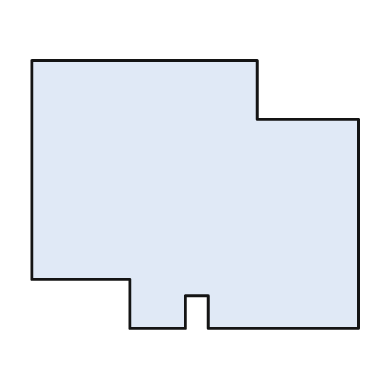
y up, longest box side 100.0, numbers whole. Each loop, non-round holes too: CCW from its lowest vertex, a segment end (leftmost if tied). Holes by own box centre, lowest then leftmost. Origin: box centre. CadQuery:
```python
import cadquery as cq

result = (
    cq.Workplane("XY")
    .moveTo(-20.0, -41.0)
    .lineTo(-3.0, -41.0)
    .lineTo(-3.0, -31.0)
    .lineTo(4.0, -31.0)
    .lineTo(4.0, -41.0)
    .lineTo(50.0, -41.0)
    .lineTo(50.0, 23.0)
    .lineTo(19.0, 23.0)
    .lineTo(19.0, 41.0)
    .lineTo(-50.0, 41.0)
    .lineTo(-50.0, -26.0)
    .lineTo(-20.0, -26.0)
    .close()
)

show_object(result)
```